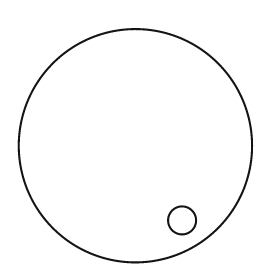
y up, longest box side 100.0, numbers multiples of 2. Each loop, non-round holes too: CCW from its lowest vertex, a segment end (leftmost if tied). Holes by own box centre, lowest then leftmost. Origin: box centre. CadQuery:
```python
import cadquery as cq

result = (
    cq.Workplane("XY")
    .moveTo(0.0, 0.0)
    .circle(50.0)
    .moveTo(20.0, -32.0)
    .circle(6.0)
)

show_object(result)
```